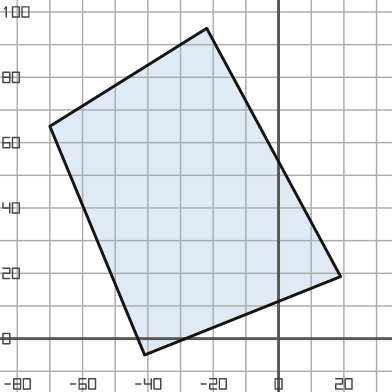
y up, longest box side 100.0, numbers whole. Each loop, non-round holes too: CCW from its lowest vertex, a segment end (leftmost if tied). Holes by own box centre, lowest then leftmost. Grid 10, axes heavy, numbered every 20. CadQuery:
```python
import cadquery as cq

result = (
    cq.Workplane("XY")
    .moveTo(-41.0, -5.0)
    .lineTo(19.0, 19.0)
    .lineTo(-22.0, 95.0)
    .lineTo(-70.0, 65.0)
    .close()
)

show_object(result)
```